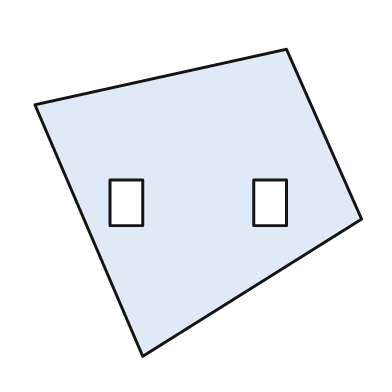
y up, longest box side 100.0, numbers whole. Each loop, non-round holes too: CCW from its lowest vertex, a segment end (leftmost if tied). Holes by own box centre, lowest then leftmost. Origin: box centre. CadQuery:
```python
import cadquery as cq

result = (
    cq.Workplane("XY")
    .moveTo(-17.0, -47.0)
    .lineTo(50.0, -5.0)
    .lineTo(27.0, 47.0)
    .lineTo(-50.0, 30.0)
    .close()
    .moveTo(-27.0, -7.0)
    .lineTo(-17.0, -7.0)
    .lineTo(-17.0, 7.0)
    .lineTo(-27.0, 7.0)
    .close()
    .moveTo(17.0, -7.0)
    .lineTo(27.0, -7.0)
    .lineTo(27.0, 7.0)
    .lineTo(17.0, 7.0)
    .close()
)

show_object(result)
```